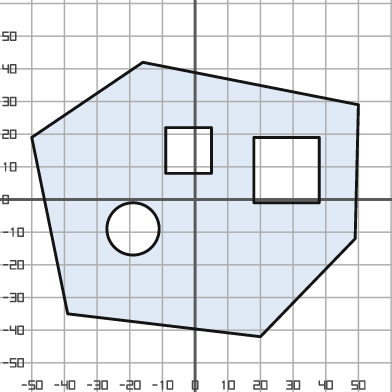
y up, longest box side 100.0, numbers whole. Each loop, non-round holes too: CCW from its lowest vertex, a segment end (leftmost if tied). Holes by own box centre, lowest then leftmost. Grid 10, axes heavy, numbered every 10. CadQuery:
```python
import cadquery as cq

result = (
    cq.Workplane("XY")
    .moveTo(20.0, -42.0)
    .lineTo(49.0, -12.0)
    .lineTo(50.0, 29.0)
    .lineTo(-16.0, 42.0)
    .lineTo(-50.0, 19.0)
    .lineTo(-39.0, -35.0)
    .close()
    .moveTo(-19.0, -9.0)
    .circle(8.0)
    .moveTo(18.0, -1.0)
    .lineTo(38.0, -1.0)
    .lineTo(38.0, 19.0)
    .lineTo(18.0, 19.0)
    .close()
    .moveTo(-9.0, 8.0)
    .lineTo(5.0, 8.0)
    .lineTo(5.0, 22.0)
    .lineTo(-9.0, 22.0)
    .close()
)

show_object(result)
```